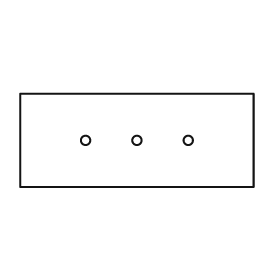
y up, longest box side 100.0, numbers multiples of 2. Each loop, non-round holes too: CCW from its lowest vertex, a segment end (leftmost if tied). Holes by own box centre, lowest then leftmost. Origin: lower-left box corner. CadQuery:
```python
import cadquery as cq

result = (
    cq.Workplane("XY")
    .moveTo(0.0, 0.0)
    .lineTo(100.0, 0.0)
    .lineTo(100.0, 40.0)
    .lineTo(0.0, 40.0)
    .close()
    .moveTo(28.0, 20.0)
    .circle(2.0)
    .moveTo(50.0, 20.0)
    .circle(2.0)
    .moveTo(72.0, 20.0)
    .circle(2.0)
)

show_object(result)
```